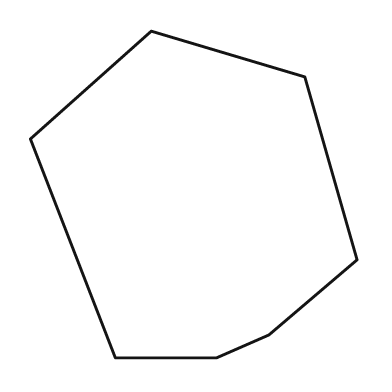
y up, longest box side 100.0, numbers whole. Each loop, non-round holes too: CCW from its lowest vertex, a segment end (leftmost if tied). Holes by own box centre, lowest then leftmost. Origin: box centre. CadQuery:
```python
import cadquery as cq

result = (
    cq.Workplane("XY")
    .moveTo(-24.0, -50.0)
    .lineTo(7.0, -50.0)
    .lineTo(23.0, -43.0)
    .lineTo(50.0, -20.0)
    .lineTo(34.0, 36.0)
    .lineTo(-13.0, 50.0)
    .lineTo(-50.0, 17.0)
    .close()
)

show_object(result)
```